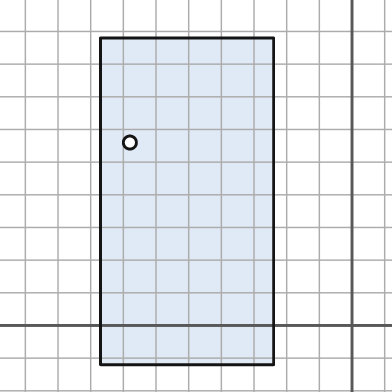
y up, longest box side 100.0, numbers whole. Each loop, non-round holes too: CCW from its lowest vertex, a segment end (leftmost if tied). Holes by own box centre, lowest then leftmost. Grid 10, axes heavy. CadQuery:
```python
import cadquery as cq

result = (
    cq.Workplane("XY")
    .moveTo(-77.0, -12.0)
    .lineTo(-24.0, -12.0)
    .lineTo(-24.0, 88.0)
    .lineTo(-77.0, 88.0)
    .close()
    .moveTo(-68.0, 56.0)
    .circle(2.0)
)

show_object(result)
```